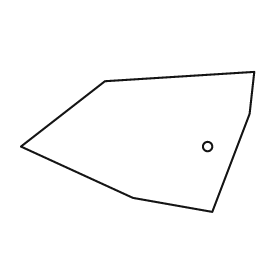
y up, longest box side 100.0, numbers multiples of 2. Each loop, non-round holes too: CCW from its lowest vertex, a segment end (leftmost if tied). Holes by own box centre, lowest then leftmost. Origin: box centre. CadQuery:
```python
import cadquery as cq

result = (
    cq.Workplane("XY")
    .moveTo(32.0, -30.0)
    .lineTo(48.0, 12.0)
    .lineTo(50.0, 30.0)
    .lineTo(-14.0, 26.0)
    .lineTo(-50.0, -2.0)
    .lineTo(-2.0, -24.0)
    .close()
    .moveTo(30.0, -2.0)
    .circle(2.0)
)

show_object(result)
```